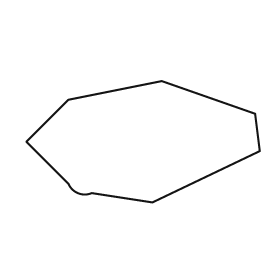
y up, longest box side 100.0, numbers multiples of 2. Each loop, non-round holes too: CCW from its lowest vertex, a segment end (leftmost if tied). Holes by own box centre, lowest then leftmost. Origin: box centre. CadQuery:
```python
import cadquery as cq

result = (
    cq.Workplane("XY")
    .moveTo(4.0, -26.0)
    .lineTo(50.0, -4.0)
    .lineTo(48.0, 12.0)
    .lineTo(8.0, 26.0)
    .lineTo(-32.0, 18.0)
    .lineTo(-50.0, 0.0)
    .lineTo(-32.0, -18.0)
    .threePointArc((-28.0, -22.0), (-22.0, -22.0))
    .close()
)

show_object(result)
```